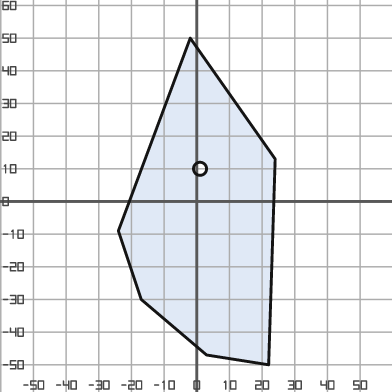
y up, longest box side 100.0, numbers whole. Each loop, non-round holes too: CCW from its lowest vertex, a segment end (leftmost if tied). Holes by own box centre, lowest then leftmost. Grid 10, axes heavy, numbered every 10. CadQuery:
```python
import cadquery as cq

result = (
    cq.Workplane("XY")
    .moveTo(22.0, -50.0)
    .lineTo(24.0, 13.0)
    .lineTo(-2.0, 50.0)
    .lineTo(-24.0, -9.0)
    .lineTo(-17.0, -30.0)
    .lineTo(3.0, -47.0)
    .close()
    .moveTo(1.0, 10.0)
    .circle(2.0)
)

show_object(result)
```